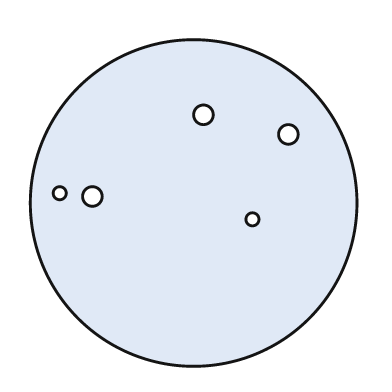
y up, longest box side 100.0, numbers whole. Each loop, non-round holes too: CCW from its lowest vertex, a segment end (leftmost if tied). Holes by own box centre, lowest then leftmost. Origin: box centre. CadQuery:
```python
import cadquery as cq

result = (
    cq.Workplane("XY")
    .moveTo(0.0, 0.0)
    .circle(50.0)
    .moveTo(18.0, -5.0)
    .circle(2.0)
    .moveTo(-31.0, 2.0)
    .circle(3.0)
    .moveTo(-41.0, 3.0)
    .circle(2.0)
    .moveTo(29.0, 21.0)
    .circle(3.0)
    .moveTo(3.0, 27.0)
    .circle(3.0)
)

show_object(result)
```